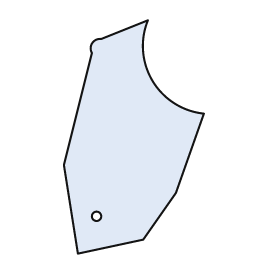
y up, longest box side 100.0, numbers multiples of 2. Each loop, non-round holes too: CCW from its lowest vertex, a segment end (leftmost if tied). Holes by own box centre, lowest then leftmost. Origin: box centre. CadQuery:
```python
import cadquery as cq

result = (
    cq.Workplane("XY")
    .moveTo(-24.0, -50.0)
    .lineTo(4.0, -44.0)
    .lineTo(18.0, -24.0)
    .lineTo(30.0, 10.0)
    .threePointArc((8.0, 24.0), (6.0, 50.0))
    .lineTo(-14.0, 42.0)
    .threePointArc((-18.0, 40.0), (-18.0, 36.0))
    .lineTo(-30.0, -12.0)
    .close()
    .moveTo(-16.0, -34.0)
    .circle(2.0)
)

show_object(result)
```